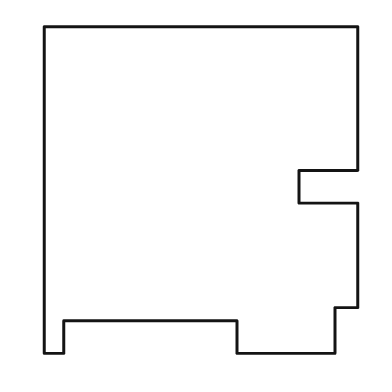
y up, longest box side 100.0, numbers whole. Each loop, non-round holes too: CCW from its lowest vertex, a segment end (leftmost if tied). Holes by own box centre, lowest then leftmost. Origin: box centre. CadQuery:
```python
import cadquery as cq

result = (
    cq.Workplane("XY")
    .moveTo(-48.0, -50.0)
    .lineTo(-42.0, -50.0)
    .lineTo(-42.0, -40.0)
    .lineTo(11.0, -40.0)
    .lineTo(11.0, -50.0)
    .lineTo(41.0, -50.0)
    .lineTo(41.0, -36.0)
    .lineTo(48.0, -36.0)
    .lineTo(48.0, -4.0)
    .lineTo(30.0, -4.0)
    .lineTo(30.0, 6.0)
    .lineTo(48.0, 6.0)
    .lineTo(48.0, 50.0)
    .lineTo(-48.0, 50.0)
    .close()
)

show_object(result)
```